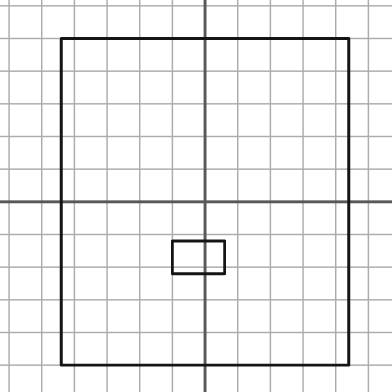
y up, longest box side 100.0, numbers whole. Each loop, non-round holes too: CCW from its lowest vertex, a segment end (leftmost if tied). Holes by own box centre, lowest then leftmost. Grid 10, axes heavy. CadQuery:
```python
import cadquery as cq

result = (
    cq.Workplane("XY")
    .moveTo(-44.0, -50.0)
    .lineTo(44.0, -50.0)
    .lineTo(44.0, 50.0)
    .lineTo(-44.0, 50.0)
    .close()
    .moveTo(-10.0, -22.0)
    .lineTo(6.0, -22.0)
    .lineTo(6.0, -12.0)
    .lineTo(-10.0, -12.0)
    .close()
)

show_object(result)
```